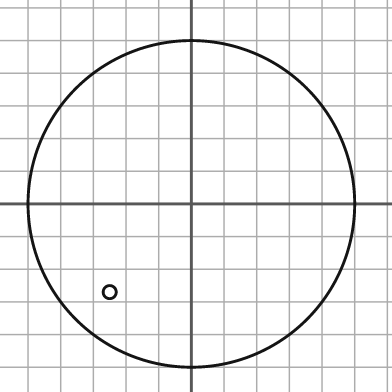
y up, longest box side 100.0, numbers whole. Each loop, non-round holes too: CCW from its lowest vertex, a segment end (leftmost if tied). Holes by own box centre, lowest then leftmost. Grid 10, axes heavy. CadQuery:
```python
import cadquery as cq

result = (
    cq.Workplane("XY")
    .moveTo(0.0, 0.0)
    .circle(50.0)
    .moveTo(-25.0, -27.0)
    .circle(2.0)
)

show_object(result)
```